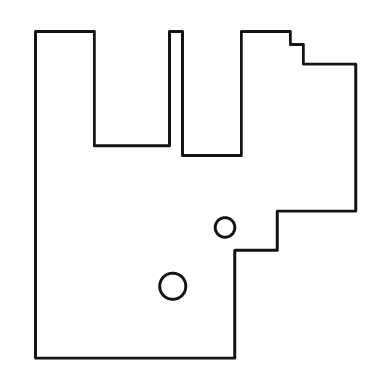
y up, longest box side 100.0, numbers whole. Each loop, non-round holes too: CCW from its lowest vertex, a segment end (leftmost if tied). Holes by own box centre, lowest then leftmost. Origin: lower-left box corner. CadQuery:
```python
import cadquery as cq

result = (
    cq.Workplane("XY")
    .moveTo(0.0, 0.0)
    .lineTo(61.0, 0.0)
    .lineTo(61.0, 33.0)
    .lineTo(74.0, 33.0)
    .lineTo(74.0, 45.0)
    .lineTo(98.0, 45.0)
    .lineTo(98.0, 90.0)
    .lineTo(82.0, 90.0)
    .lineTo(82.0, 96.0)
    .lineTo(78.0, 96.0)
    .lineTo(78.0, 100.0)
    .lineTo(63.0, 100.0)
    .lineTo(63.0, 62.0)
    .lineTo(45.0, 62.0)
    .lineTo(45.0, 100.0)
    .lineTo(41.0, 100.0)
    .lineTo(41.0, 65.0)
    .lineTo(18.0, 65.0)
    .lineTo(18.0, 100.0)
    .lineTo(0.0, 100.0)
    .close()
    .moveTo(42.0, 22.0)
    .circle(4.0)
    .moveTo(58.0, 40.0)
    .circle(3.0)
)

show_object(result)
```